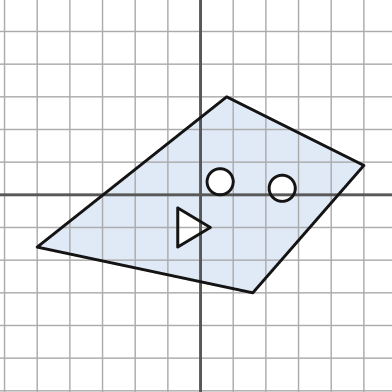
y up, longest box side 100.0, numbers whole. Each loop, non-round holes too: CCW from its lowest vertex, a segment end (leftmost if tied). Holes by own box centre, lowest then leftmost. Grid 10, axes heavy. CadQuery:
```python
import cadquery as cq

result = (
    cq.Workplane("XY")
    .moveTo(16.0, -30.0)
    .lineTo(50.0, 9.0)
    .lineTo(8.0, 30.0)
    .lineTo(-50.0, -16.0)
    .close()
    .moveTo(-7.0, -16.0)
    .lineTo(3.0, -10.0)
    .lineTo(-7.0, -4.0)
    .close()
    .moveTo(25.0, 2.0)
    .circle(4.0)
    .moveTo(6.0, 4.0)
    .circle(4.0)
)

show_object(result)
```